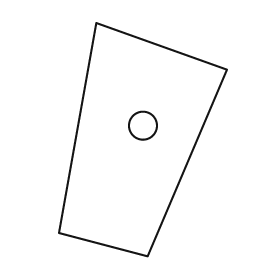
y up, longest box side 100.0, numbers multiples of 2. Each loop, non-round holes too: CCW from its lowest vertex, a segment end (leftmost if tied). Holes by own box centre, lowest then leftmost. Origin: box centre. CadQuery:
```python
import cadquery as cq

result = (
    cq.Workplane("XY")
    .moveTo(2.0, -50.0)
    .lineTo(36.0, 30.0)
    .lineTo(-20.0, 50.0)
    .lineTo(-36.0, -40.0)
    .close()
    .moveTo(0.0, 6.0)
    .circle(6.0)
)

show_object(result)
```